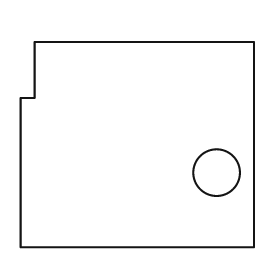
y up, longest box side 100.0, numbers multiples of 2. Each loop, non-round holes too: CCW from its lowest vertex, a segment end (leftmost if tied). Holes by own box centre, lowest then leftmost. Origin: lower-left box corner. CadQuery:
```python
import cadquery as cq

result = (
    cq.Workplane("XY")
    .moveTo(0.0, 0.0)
    .lineTo(100.0, 0.0)
    .lineTo(100.0, 88.0)
    .lineTo(6.0, 88.0)
    .lineTo(6.0, 64.0)
    .lineTo(0.0, 64.0)
    .close()
    .moveTo(84.0, 32.0)
    .circle(10.0)
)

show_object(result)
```